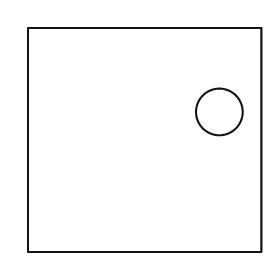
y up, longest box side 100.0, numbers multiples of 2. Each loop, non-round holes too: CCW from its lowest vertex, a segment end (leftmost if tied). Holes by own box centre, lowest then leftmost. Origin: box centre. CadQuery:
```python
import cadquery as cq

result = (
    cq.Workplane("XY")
    .moveTo(-50.0, -48.0)
    .lineTo(50.0, -48.0)
    .lineTo(50.0, 48.0)
    .lineTo(-50.0, 48.0)
    .close()
    .moveTo(32.0, 12.0)
    .circle(10.0)
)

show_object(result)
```